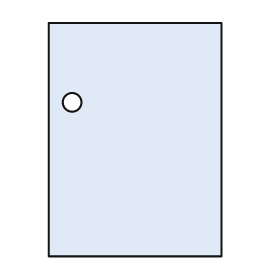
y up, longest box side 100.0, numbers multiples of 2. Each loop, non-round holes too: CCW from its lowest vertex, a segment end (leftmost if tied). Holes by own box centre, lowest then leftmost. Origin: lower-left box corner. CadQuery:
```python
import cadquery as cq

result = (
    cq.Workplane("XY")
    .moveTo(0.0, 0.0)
    .lineTo(74.0, 0.0)
    .lineTo(74.0, 100.0)
    .lineTo(0.0, 100.0)
    .close()
    .moveTo(10.0, 66.0)
    .circle(4.0)
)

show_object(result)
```